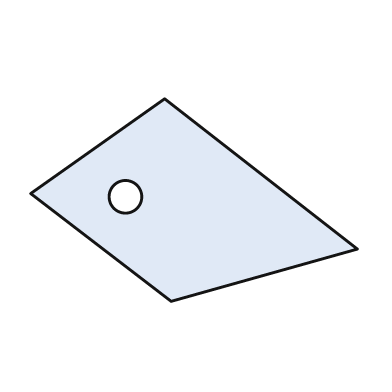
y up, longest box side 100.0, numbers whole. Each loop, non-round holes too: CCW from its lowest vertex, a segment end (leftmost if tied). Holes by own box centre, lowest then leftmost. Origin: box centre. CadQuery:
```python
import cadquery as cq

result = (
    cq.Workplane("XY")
    .moveTo(-7.0, -31.0)
    .lineTo(50.0, -15.0)
    .lineTo(-9.0, 31.0)
    .lineTo(-50.0, 2.0)
    .close()
    .moveTo(-21.0, 1.0)
    .circle(5.0)
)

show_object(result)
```